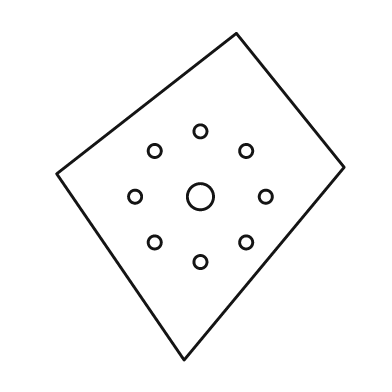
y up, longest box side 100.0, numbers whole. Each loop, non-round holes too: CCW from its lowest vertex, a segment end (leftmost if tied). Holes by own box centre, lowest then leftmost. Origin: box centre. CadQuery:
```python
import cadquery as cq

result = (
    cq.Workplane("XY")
    .moveTo(-5.0, -50.0)
    .lineTo(44.0, 9.0)
    .lineTo(11.0, 50.0)
    .lineTo(-44.0, 7.0)
    .close()
    .moveTo(0.0, -20.0)
    .circle(2.0)
    .moveTo(-14.0, -14.0)
    .circle(2.0)
    .moveTo(14.0, -14.0)
    .circle(2.0)
    .moveTo(-20.0, 0.0)
    .circle(2.0)
    .moveTo(0.0, 0.0)
    .circle(4.0)
    .moveTo(20.0, 0.0)
    .circle(2.0)
    .moveTo(-14.0, 14.0)
    .circle(2.0)
    .moveTo(14.0, 14.0)
    .circle(2.0)
    .moveTo(0.0, 20.0)
    .circle(2.0)
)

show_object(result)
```